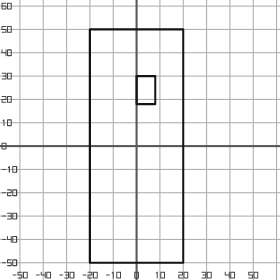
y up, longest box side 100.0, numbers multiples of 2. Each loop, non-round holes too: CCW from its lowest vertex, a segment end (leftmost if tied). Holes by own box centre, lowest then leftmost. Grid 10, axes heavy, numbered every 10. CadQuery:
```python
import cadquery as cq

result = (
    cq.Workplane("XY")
    .moveTo(-20.0, -50.0)
    .lineTo(20.0, -50.0)
    .lineTo(20.0, 50.0)
    .lineTo(-20.0, 50.0)
    .close()
    .moveTo(0.0, 18.0)
    .lineTo(8.0, 18.0)
    .lineTo(8.0, 30.0)
    .lineTo(0.0, 30.0)
    .close()
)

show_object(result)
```